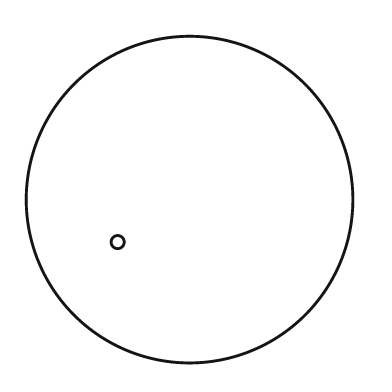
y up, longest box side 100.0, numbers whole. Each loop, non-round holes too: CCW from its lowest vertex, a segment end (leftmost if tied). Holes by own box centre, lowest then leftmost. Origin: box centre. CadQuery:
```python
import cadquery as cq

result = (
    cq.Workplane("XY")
    .moveTo(0.0, 0.0)
    .circle(50.0)
    .moveTo(-22.0, -13.0)
    .circle(2.0)
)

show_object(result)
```